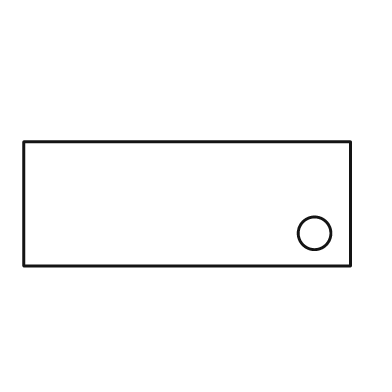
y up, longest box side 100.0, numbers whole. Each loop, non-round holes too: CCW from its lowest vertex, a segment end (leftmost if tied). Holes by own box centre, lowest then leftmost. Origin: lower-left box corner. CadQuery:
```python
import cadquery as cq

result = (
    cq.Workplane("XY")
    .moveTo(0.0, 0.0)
    .lineTo(100.0, 0.0)
    .lineTo(100.0, 38.0)
    .lineTo(0.0, 38.0)
    .close()
    .moveTo(89.0, 10.0)
    .circle(5.0)
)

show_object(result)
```